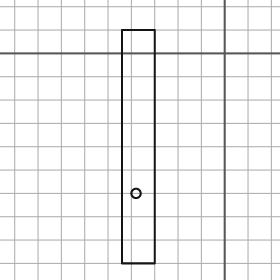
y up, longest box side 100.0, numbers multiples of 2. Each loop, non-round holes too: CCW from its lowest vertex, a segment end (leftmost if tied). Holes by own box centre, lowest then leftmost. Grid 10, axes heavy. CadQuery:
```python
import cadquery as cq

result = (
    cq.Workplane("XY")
    .moveTo(-44.0, -90.0)
    .lineTo(-30.0, -90.0)
    .lineTo(-30.0, 10.0)
    .lineTo(-44.0, 10.0)
    .close()
    .moveTo(-38.0, -60.0)
    .circle(2.0)
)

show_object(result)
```